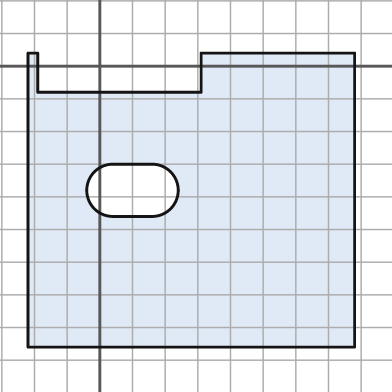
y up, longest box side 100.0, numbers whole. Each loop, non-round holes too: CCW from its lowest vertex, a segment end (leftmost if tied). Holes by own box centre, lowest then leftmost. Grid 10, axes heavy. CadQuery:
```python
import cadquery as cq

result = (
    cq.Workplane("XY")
    .moveTo(-22.0, -86.0)
    .lineTo(78.0, -86.0)
    .lineTo(78.0, 4.0)
    .lineTo(31.0, 4.0)
    .lineTo(31.0, -8.0)
    .lineTo(-19.0, -8.0)
    .lineTo(-19.0, 4.0)
    .lineTo(-22.0, 4.0)
    .close()
    .moveTo(4.0, -46.0)
    .lineTo(16.0, -46.0)
    .threePointArc((24.0, -38.0), (16.0, -30.0))
    .lineTo(4.0, -30.0)
    .threePointArc((-4.0, -38.0), (4.0, -46.0))
    .close()
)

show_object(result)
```